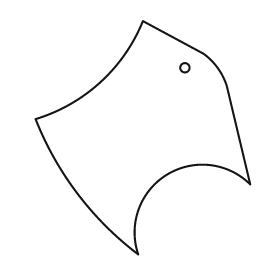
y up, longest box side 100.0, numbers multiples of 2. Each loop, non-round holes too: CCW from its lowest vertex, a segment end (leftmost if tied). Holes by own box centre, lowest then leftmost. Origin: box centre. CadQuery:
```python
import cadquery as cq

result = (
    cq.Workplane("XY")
    .moveTo(-2.0, -50.0)
    .threePointArc((10.0, -16.0), (46.0, -20.0))
    .lineTo(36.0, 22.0)
    .threePointArc((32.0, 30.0), (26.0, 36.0))
    .lineTo(0.0, 50.0)
    .threePointArc((-18.0, 24.0), (-46.0, 8.0))
    .threePointArc((-28.0, -24.0), (-2.0, -50.0))
    .close()
    .moveTo(18.0, 30.0)
    .circle(2.0)
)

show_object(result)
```